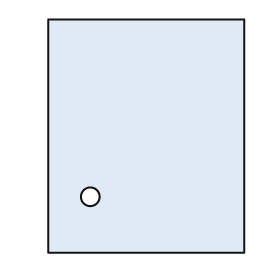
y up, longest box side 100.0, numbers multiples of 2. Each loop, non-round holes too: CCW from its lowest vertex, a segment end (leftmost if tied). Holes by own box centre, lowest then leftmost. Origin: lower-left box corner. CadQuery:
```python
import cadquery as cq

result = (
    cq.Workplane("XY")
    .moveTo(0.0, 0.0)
    .lineTo(84.0, 0.0)
    .lineTo(84.0, 100.0)
    .lineTo(0.0, 100.0)
    .close()
    .moveTo(18.0, 24.0)
    .circle(4.0)
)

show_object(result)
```